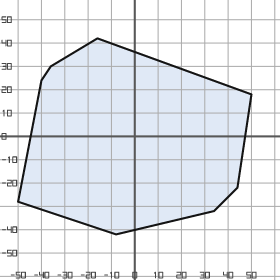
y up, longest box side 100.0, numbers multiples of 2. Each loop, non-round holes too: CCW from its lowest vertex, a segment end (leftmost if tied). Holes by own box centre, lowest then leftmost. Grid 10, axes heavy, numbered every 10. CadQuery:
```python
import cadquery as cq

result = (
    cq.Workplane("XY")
    .moveTo(-8.0, -42.0)
    .lineTo(34.0, -32.0)
    .lineTo(44.0, -22.0)
    .lineTo(50.0, 18.0)
    .lineTo(-16.0, 42.0)
    .lineTo(-36.0, 30.0)
    .lineTo(-40.0, 24.0)
    .lineTo(-50.0, -28.0)
    .close()
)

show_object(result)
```